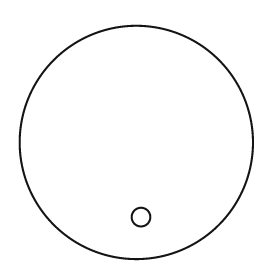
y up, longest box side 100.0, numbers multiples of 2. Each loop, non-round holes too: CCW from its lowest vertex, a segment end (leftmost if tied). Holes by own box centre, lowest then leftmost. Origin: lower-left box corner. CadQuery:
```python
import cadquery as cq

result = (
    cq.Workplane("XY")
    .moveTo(50.0, 50.0)
    .circle(50.0)
    .moveTo(52.0, 18.0)
    .circle(4.0)
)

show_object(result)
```